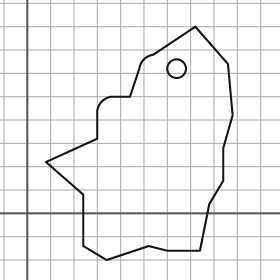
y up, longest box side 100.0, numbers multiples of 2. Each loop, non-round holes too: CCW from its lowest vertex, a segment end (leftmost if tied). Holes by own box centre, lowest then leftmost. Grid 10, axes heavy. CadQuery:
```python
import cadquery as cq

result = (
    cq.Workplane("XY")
    .moveTo(34.0, -20.0)
    .lineTo(52.0, -14.0)
    .lineTo(60.0, -16.0)
    .lineTo(74.0, -16.0)
    .lineTo(78.0, 4.0)
    .lineTo(84.0, 14.0)
    .lineTo(84.0, 28.0)
    .lineTo(88.0, 42.0)
    .lineTo(86.0, 64.0)
    .lineTo(72.0, 80.0)
    .lineTo(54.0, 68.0)
    .threePointArc((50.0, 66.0), (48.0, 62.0))
    .lineTo(44.0, 50.0)
    .lineTo(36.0, 50.0)
    .threePointArc((32.0, 48.0), (30.0, 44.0))
    .lineTo(30.0, 32.0)
    .lineTo(8.0, 22.0)
    .lineTo(24.0, 8.0)
    .lineTo(24.0, -14.0)
    .close()
    .moveTo(64.0, 62.0)
    .circle(4.0)
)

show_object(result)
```